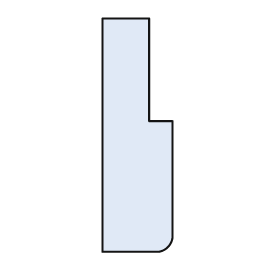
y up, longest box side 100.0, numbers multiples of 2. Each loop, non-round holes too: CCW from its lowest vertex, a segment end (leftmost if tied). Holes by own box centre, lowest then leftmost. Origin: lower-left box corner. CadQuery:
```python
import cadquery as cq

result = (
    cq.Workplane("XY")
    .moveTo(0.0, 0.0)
    .lineTo(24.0, 0.0)
    .threePointArc((28.0, 2.0), (30.0, 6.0))
    .lineTo(30.0, 56.0)
    .lineTo(20.0, 56.0)
    .lineTo(20.0, 100.0)
    .lineTo(0.0, 100.0)
    .close()
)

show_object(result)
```